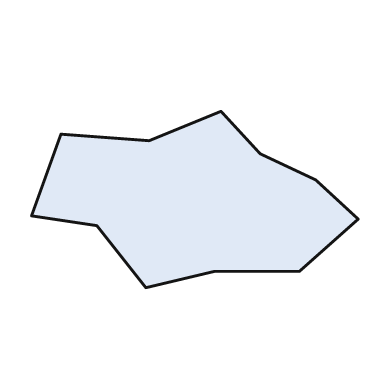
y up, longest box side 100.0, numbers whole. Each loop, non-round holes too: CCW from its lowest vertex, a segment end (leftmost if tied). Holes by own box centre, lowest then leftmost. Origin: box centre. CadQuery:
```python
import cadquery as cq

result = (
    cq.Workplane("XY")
    .moveTo(-15.0, -27.0)
    .lineTo(6.0, -22.0)
    .lineTo(32.0, -22.0)
    .lineTo(50.0, -6.0)
    .lineTo(37.0, 6.0)
    .lineTo(20.0, 14.0)
    .lineTo(8.0, 27.0)
    .lineTo(-14.0, 18.0)
    .lineTo(-41.0, 20.0)
    .lineTo(-50.0, -5.0)
    .lineTo(-30.0, -8.0)
    .close()
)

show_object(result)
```